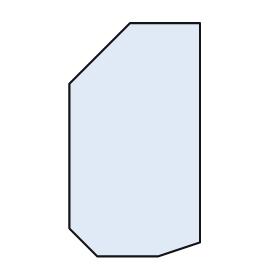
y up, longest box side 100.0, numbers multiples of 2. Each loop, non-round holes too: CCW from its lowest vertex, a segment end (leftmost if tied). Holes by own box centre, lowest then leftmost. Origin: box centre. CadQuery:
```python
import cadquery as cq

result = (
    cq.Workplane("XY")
    .moveTo(-16.0, -50.0)
    .lineTo(10.0, -50.0)
    .lineTo(28.0, -44.0)
    .lineTo(28.0, 50.0)
    .lineTo(-2.0, 50.0)
    .lineTo(-28.0, 24.0)
    .lineTo(-28.0, -38.0)
    .close()
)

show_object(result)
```